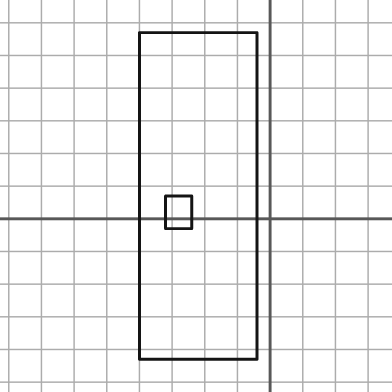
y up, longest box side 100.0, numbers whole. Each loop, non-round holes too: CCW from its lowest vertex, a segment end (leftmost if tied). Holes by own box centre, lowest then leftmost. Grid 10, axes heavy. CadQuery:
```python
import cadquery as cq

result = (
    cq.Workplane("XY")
    .moveTo(-40.0, -43.0)
    .lineTo(-4.0, -43.0)
    .lineTo(-4.0, 57.0)
    .lineTo(-40.0, 57.0)
    .close()
    .moveTo(-32.0, -3.0)
    .lineTo(-24.0, -3.0)
    .lineTo(-24.0, 7.0)
    .lineTo(-32.0, 7.0)
    .close()
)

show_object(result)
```